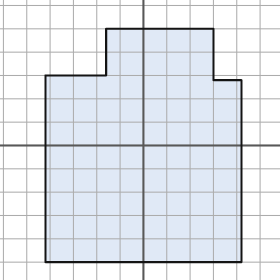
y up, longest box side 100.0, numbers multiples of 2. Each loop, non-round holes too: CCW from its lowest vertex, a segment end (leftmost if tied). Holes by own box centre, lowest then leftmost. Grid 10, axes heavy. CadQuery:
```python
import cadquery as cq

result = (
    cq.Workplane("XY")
    .moveTo(-42.0, -50.0)
    .lineTo(42.0, -50.0)
    .lineTo(42.0, 28.0)
    .lineTo(30.0, 28.0)
    .lineTo(30.0, 50.0)
    .lineTo(-16.0, 50.0)
    .lineTo(-16.0, 30.0)
    .lineTo(-42.0, 30.0)
    .close()
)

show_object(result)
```